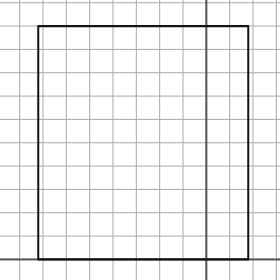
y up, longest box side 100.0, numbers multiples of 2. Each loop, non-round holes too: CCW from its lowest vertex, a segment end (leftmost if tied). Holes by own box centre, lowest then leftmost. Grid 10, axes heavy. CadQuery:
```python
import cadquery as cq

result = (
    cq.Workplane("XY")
    .moveTo(-72.0, 0.0)
    .lineTo(18.0, 0.0)
    .lineTo(18.0, 100.0)
    .lineTo(-72.0, 100.0)
    .close()
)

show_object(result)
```